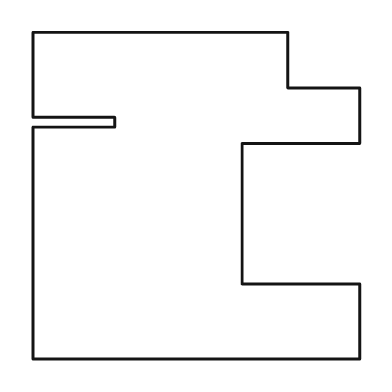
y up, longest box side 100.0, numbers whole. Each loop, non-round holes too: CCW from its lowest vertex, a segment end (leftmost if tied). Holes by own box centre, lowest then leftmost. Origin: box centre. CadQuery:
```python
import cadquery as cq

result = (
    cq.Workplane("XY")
    .moveTo(-50.0, -50.0)
    .lineTo(50.0, -50.0)
    .lineTo(50.0, -27.0)
    .lineTo(14.0, -27.0)
    .lineTo(14.0, 16.0)
    .lineTo(50.0, 16.0)
    .lineTo(50.0, 33.0)
    .lineTo(28.0, 33.0)
    .lineTo(28.0, 50.0)
    .lineTo(-50.0, 50.0)
    .lineTo(-50.0, 24.0)
    .lineTo(-25.0, 24.0)
    .lineTo(-25.0, 21.0)
    .lineTo(-50.0, 21.0)
    .close()
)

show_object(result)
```